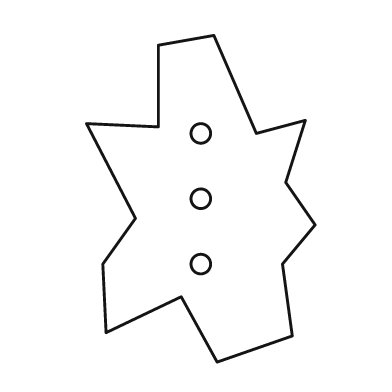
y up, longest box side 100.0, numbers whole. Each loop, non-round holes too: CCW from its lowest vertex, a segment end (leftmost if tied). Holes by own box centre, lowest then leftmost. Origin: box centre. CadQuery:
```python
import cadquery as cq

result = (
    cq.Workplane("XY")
    .moveTo(5.0, -50.0)
    .lineTo(28.0, -42.0)
    .lineTo(25.0, -20.0)
    .lineTo(35.0, -8.0)
    .lineTo(26.0, 5.0)
    .lineTo(32.0, 24.0)
    .lineTo(17.0, 20.0)
    .lineTo(4.0, 50.0)
    .lineTo(-13.0, 47.0)
    .lineTo(-13.0, 22.0)
    .lineTo(-35.0, 23.0)
    .lineTo(-20.0, -6.0)
    .lineTo(-30.0, -20.0)
    .lineTo(-29.0, -41.0)
    .lineTo(-6.0, -30.0)
    .close()
    .moveTo(0.0, -20.0)
    .circle(3.0)
    .moveTo(0.0, 0.0)
    .circle(3.0)
    .moveTo(0.0, 20.0)
    .circle(3.0)
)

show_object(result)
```